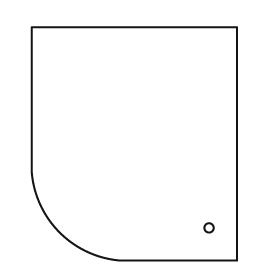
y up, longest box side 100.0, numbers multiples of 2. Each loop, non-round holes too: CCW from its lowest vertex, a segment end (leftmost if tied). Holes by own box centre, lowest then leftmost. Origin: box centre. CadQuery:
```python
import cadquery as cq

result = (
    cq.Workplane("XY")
    .moveTo(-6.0, -50.0)
    .lineTo(44.0, -50.0)
    .lineTo(44.0, 50.0)
    .lineTo(-44.0, 50.0)
    .lineTo(-44.0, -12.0)
    .threePointArc((-32.0, -38.0), (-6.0, -50.0))
    .close()
    .moveTo(32.0, -36.0)
    .circle(2.0)
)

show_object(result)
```